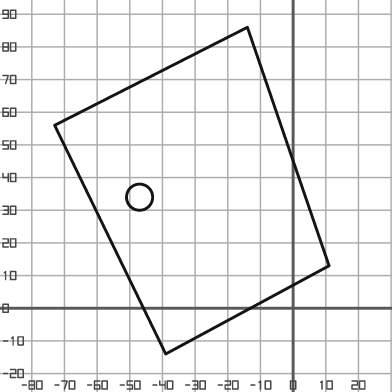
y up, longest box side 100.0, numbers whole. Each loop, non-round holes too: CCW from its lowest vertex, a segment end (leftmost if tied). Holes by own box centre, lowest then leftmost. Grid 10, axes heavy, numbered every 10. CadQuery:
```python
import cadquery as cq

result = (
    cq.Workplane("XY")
    .moveTo(-39.0, -14.0)
    .lineTo(11.0, 13.0)
    .lineTo(-14.0, 86.0)
    .lineTo(-73.0, 56.0)
    .close()
    .moveTo(-47.0, 34.0)
    .circle(4.0)
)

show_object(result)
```